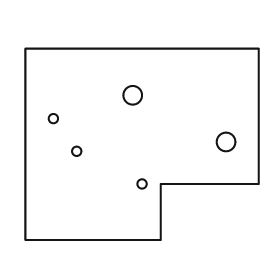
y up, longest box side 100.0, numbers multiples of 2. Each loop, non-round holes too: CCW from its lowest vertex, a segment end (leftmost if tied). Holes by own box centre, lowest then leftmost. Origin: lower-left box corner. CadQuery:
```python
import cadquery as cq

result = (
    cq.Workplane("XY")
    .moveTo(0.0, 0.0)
    .lineTo(58.0, 0.0)
    .lineTo(58.0, 24.0)
    .lineTo(100.0, 24.0)
    .lineTo(100.0, 82.0)
    .lineTo(0.0, 82.0)
    .close()
    .moveTo(50.0, 24.0)
    .circle(2.0)
    .moveTo(22.0, 38.0)
    .circle(2.0)
    .moveTo(86.0, 42.0)
    .circle(4.0)
    .moveTo(12.0, 52.0)
    .circle(2.0)
    .moveTo(46.0, 62.0)
    .circle(4.0)
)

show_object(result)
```